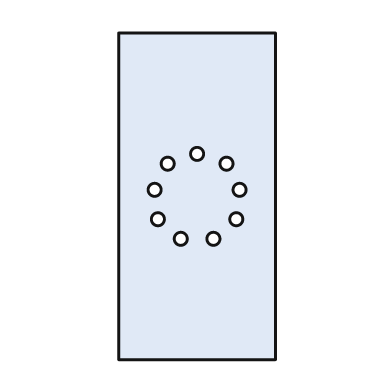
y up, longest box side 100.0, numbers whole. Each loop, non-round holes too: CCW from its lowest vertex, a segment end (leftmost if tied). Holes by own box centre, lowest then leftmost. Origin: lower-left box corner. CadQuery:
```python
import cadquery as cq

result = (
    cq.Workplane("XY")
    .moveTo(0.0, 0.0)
    .lineTo(48.0, 0.0)
    .lineTo(48.0, 100.0)
    .lineTo(0.0, 100.0)
    .close()
    .moveTo(19.0, 37.0)
    .circle(2.0)
    .moveTo(29.0, 37.0)
    .circle(2.0)
    .moveTo(12.0, 43.0)
    .circle(2.0)
    .moveTo(36.0, 43.0)
    .circle(2.0)
    .moveTo(11.0, 52.0)
    .circle(2.0)
    .moveTo(37.0, 52.0)
    .circle(2.0)
    .moveTo(15.0, 60.0)
    .circle(2.0)
    .moveTo(33.0, 60.0)
    .circle(2.0)
    .moveTo(24.0, 63.0)
    .circle(2.0)
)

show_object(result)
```